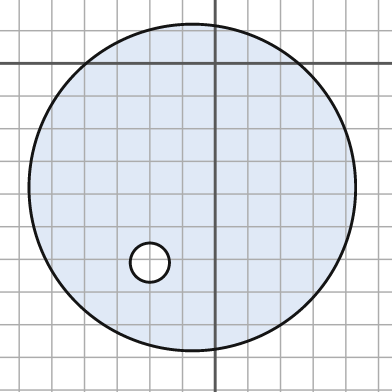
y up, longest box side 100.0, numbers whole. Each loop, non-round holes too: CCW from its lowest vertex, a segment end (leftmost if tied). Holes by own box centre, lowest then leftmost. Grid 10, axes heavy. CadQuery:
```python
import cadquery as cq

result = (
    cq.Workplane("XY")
    .moveTo(-7.0, -38.0)
    .circle(50.0)
    .moveTo(-20.0, -61.0)
    .circle(6.0)
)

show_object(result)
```